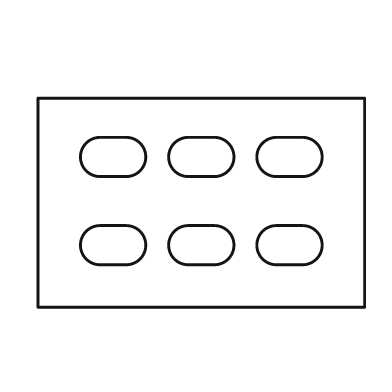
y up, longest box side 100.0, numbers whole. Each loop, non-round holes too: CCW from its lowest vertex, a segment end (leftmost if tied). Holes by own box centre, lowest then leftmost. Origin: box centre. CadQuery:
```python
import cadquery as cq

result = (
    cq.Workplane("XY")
    .moveTo(-50.0, -32.0)
    .lineTo(50.0, -32.0)
    .lineTo(50.0, 32.0)
    .lineTo(-50.0, 32.0)
    .close()
    .moveTo(-31.0, -19.0)
    .lineTo(-23.0, -19.0)
    .threePointArc((-17.0, -13.0), (-23.0, -7.0))
    .lineTo(-31.0, -7.0)
    .threePointArc((-37.0, -13.0), (-31.0, -19.0))
    .close()
    .moveTo(-4.0, -19.0)
    .lineTo(4.0, -19.0)
    .threePointArc((10.0, -13.0), (4.0, -7.0))
    .lineTo(-4.0, -7.0)
    .threePointArc((-10.0, -13.0), (-4.0, -19.0))
    .close()
    .moveTo(23.0, -19.0)
    .lineTo(31.0, -19.0)
    .threePointArc((37.0, -13.0), (31.0, -7.0))
    .lineTo(23.0, -7.0)
    .threePointArc((17.0, -13.0), (23.0, -19.0))
    .close()
    .moveTo(-31.0, 8.0)
    .lineTo(-23.0, 8.0)
    .threePointArc((-17.0, 14.0), (-23.0, 20.0))
    .lineTo(-31.0, 20.0)
    .threePointArc((-37.0, 14.0), (-31.0, 8.0))
    .close()
    .moveTo(-4.0, 8.0)
    .lineTo(4.0, 8.0)
    .threePointArc((10.0, 14.0), (4.0, 20.0))
    .lineTo(-4.0, 20.0)
    .threePointArc((-10.0, 14.0), (-4.0, 8.0))
    .close()
    .moveTo(23.0, 8.0)
    .lineTo(31.0, 8.0)
    .threePointArc((37.0, 14.0), (31.0, 20.0))
    .lineTo(23.0, 20.0)
    .threePointArc((17.0, 14.0), (23.0, 8.0))
    .close()
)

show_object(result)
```